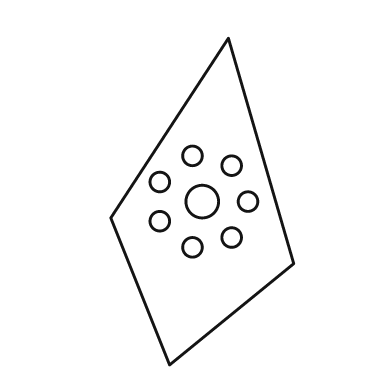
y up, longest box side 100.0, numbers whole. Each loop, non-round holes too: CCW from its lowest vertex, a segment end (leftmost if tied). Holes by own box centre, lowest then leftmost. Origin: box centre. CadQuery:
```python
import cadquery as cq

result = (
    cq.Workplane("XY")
    .moveTo(-10.0, -50.0)
    .lineTo(28.0, -19.0)
    .lineTo(8.0, 50.0)
    .lineTo(-28.0, -5.0)
    .close()
    .moveTo(-3.0, -14.0)
    .circle(3.0)
    .moveTo(9.0, -11.0)
    .circle(3.0)
    .moveTo(-13.0, -6.0)
    .circle(3.0)
    .moveTo(0.0, 0.0)
    .circle(5.0)
    .moveTo(14.0, 0.0)
    .circle(3.0)
    .moveTo(-13.0, 6.0)
    .circle(3.0)
    .moveTo(9.0, 11.0)
    .circle(3.0)
    .moveTo(-3.0, 14.0)
    .circle(3.0)
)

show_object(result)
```